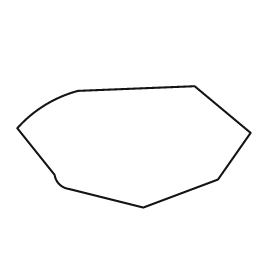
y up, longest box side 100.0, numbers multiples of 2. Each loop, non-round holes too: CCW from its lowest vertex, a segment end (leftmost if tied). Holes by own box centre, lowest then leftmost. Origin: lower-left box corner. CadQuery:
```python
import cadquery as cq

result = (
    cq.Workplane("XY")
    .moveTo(54.0, 0.0)
    .lineTo(86.0, 12.0)
    .lineTo(100.0, 32.0)
    .lineTo(76.0, 52.0)
    .lineTo(26.0, 50.0)
    .threePointArc((12.0, 44.0), (0.0, 34.0))
    .lineTo(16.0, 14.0)
    .threePointArc((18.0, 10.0), (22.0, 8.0))
    .close()
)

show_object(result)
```